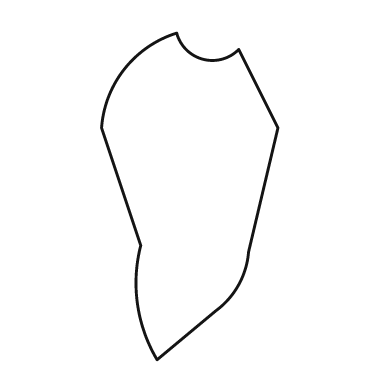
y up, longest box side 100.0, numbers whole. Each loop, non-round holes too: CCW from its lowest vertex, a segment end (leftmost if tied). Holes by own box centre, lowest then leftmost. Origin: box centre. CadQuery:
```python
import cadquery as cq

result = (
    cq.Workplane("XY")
    .moveTo(-10.0, -50.0)
    .lineTo(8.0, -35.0)
    .threePointArc((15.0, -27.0), (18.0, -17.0))
    .lineTo(27.0, 21.0)
    .lineTo(15.0, 45.0)
    .threePointArc((4.0, 42.0), (-4.0, 50.0))
    .threePointArc((-20.0, 39.0), (-27.0, 21.0))
    .lineTo(-15.0, -15.0)
    .threePointArc((-16.0, -33.0), (-10.0, -50.0))
    .close()
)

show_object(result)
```